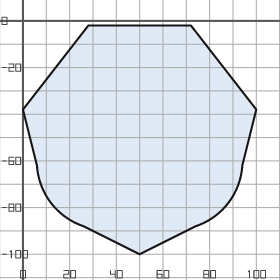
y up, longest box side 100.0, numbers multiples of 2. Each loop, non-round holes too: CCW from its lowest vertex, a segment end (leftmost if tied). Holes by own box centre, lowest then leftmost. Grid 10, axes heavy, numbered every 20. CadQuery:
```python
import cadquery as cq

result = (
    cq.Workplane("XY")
    .moveTo(50.0, -100.0)
    .lineTo(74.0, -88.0)
    .threePointArc((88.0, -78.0), (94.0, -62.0))
    .lineTo(100.0, -38.0)
    .lineTo(72.0, -2.0)
    .lineTo(28.0, -2.0)
    .lineTo(0.0, -38.0)
    .lineTo(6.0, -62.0)
    .threePointArc((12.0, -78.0), (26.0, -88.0))
    .close()
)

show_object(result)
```